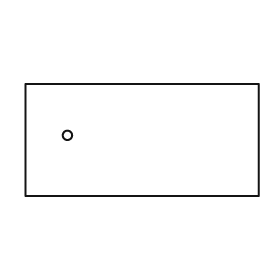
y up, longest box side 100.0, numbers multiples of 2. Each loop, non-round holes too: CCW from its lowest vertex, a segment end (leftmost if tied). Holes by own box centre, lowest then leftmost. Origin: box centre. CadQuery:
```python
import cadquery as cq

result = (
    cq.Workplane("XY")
    .moveTo(-50.0, -24.0)
    .lineTo(50.0, -24.0)
    .lineTo(50.0, 24.0)
    .lineTo(-50.0, 24.0)
    .close()
    .moveTo(-32.0, 2.0)
    .circle(2.0)
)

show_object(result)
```